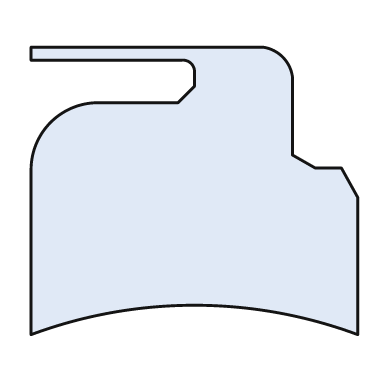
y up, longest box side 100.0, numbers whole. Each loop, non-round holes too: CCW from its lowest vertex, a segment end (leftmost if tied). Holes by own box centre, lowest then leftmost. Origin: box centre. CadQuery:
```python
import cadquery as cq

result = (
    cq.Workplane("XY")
    .moveTo(-50.0, -44.0)
    .threePointArc((0.0, -35.0), (50.0, -44.0))
    .lineTo(50.0, -2.0)
    .lineTo(45.0, 7.0)
    .lineTo(37.0, 7.0)
    .lineTo(30.0, 11.0)
    .lineTo(30.0, 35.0)
    .threePointArc((27.0, 41.0), (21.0, 44.0))
    .lineTo(-50.0, 44.0)
    .lineTo(-50.0, 40.0)
    .lineTo(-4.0, 40.0)
    .threePointArc((-1.0, 39.0), (0.0, 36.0))
    .lineTo(0.0, 32.0)
    .lineTo(-5.0, 27.0)
    .lineTo(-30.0, 27.0)
    .threePointArc((-44.0, 21.0), (-50.0, 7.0))
    .close()
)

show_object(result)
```